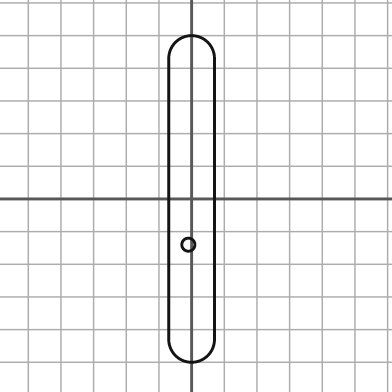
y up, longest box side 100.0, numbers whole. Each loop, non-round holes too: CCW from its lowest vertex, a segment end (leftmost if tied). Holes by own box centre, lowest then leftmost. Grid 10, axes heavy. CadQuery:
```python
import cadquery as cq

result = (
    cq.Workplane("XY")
    .moveTo(-7.0, -43.0)
    .threePointArc((0.0, -50.0), (7.0, -43.0))
    .lineTo(7.0, 43.0)
    .threePointArc((0.0, 50.0), (-7.0, 43.0))
    .close()
    .moveTo(-1.0, -14.0)
    .circle(2.0)
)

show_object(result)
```